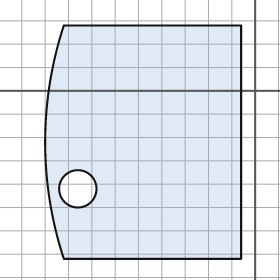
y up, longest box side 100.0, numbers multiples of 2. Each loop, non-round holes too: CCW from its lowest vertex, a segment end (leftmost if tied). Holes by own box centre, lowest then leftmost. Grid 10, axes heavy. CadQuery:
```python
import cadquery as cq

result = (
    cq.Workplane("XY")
    .moveTo(-82.0, -72.0)
    .lineTo(-6.0, -72.0)
    .lineTo(-6.0, 28.0)
    .lineTo(-82.0, 28.0)
    .threePointArc((-90.0, -22.0), (-82.0, -72.0))
    .close()
    .moveTo(-76.0, -42.0)
    .circle(8.0)
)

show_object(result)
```